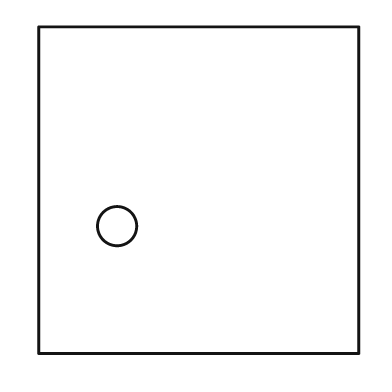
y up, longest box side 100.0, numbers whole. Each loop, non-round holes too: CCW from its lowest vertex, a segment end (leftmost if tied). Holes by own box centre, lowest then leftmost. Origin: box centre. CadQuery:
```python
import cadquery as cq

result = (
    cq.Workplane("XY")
    .moveTo(-49.0, -50.0)
    .lineTo(49.0, -50.0)
    .lineTo(49.0, 50.0)
    .lineTo(-49.0, 50.0)
    .close()
    .moveTo(-25.0, -11.0)
    .circle(6.0)
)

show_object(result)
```